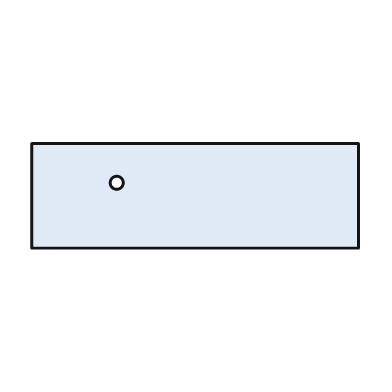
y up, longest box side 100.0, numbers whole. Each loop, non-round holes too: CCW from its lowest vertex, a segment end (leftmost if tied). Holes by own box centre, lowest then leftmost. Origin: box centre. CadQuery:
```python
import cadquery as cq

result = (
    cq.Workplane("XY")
    .moveTo(-50.0, -16.0)
    .lineTo(50.0, -16.0)
    .lineTo(50.0, 16.0)
    .lineTo(-50.0, 16.0)
    .close()
    .moveTo(-24.0, 4.0)
    .circle(2.0)
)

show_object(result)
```